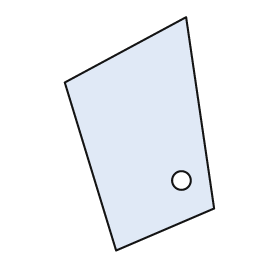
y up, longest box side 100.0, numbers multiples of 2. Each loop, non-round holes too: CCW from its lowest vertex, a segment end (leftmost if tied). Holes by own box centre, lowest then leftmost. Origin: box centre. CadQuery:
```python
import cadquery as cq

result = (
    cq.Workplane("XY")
    .moveTo(-10.0, -50.0)
    .lineTo(32.0, -32.0)
    .lineTo(20.0, 50.0)
    .lineTo(-32.0, 22.0)
    .close()
    .moveTo(18.0, -20.0)
    .circle(4.0)
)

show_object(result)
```